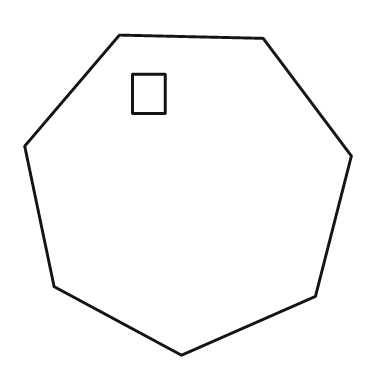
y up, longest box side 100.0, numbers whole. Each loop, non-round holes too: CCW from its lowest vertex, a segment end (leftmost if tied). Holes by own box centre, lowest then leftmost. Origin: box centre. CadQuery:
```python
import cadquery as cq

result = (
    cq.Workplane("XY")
    .moveTo(-2.0, -49.0)
    .lineTo(39.0, -31.0)
    .lineTo(50.0, 12.0)
    .lineTo(23.0, 48.0)
    .lineTo(-21.0, 49.0)
    .lineTo(-50.0, 15.0)
    .lineTo(-41.0, -28.0)
    .close()
    .moveTo(-17.0, 25.0)
    .lineTo(-7.0, 25.0)
    .lineTo(-7.0, 37.0)
    .lineTo(-17.0, 37.0)
    .close()
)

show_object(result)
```